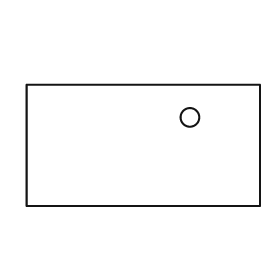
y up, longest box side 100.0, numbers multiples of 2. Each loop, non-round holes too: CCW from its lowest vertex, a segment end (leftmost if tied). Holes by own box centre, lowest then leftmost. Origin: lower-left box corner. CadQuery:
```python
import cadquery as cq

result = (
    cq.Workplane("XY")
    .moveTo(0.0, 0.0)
    .lineTo(100.0, 0.0)
    .lineTo(100.0, 52.0)
    .lineTo(0.0, 52.0)
    .close()
    .moveTo(70.0, 38.0)
    .circle(4.0)
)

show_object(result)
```